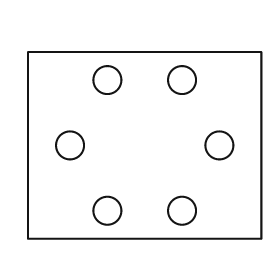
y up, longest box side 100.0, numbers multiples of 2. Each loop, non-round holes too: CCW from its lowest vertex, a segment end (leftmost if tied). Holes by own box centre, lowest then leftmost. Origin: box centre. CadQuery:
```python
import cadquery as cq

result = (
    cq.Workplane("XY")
    .moveTo(-50.0, -40.0)
    .lineTo(50.0, -40.0)
    .lineTo(50.0, 40.0)
    .lineTo(-50.0, 40.0)
    .close()
    .moveTo(-16.0, -28.0)
    .circle(6.0)
    .moveTo(16.0, -28.0)
    .circle(6.0)
    .moveTo(-32.0, 0.0)
    .circle(6.0)
    .moveTo(32.0, 0.0)
    .circle(6.0)
    .moveTo(-16.0, 28.0)
    .circle(6.0)
    .moveTo(16.0, 28.0)
    .circle(6.0)
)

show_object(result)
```